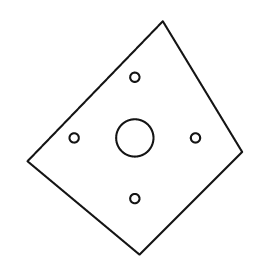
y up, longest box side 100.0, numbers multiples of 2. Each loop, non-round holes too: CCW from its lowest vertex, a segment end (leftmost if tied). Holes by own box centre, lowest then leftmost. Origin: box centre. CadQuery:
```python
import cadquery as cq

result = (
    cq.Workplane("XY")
    .moveTo(2.0, -50.0)
    .lineTo(46.0, -6.0)
    .lineTo(12.0, 50.0)
    .lineTo(-46.0, -10.0)
    .close()
    .moveTo(0.0, -26.0)
    .circle(2.0)
    .moveTo(-26.0, 0.0)
    .circle(2.0)
    .moveTo(0.0, 0.0)
    .circle(8.0)
    .moveTo(26.0, 0.0)
    .circle(2.0)
    .moveTo(0.0, 26.0)
    .circle(2.0)
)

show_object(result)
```